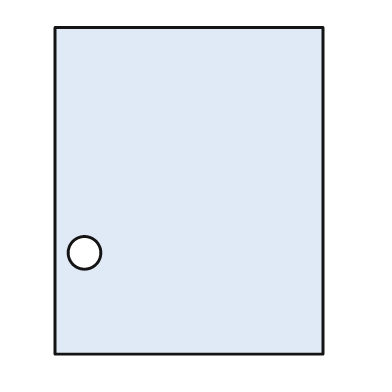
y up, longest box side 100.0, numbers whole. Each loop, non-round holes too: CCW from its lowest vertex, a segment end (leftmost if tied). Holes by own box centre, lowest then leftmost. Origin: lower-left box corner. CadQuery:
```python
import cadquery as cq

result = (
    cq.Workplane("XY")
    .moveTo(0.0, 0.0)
    .lineTo(82.0, 0.0)
    .lineTo(82.0, 100.0)
    .lineTo(0.0, 100.0)
    .close()
    .moveTo(9.0, 31.0)
    .circle(5.0)
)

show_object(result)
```